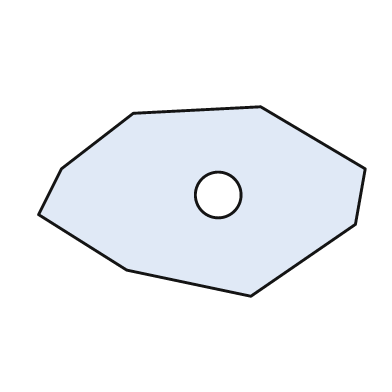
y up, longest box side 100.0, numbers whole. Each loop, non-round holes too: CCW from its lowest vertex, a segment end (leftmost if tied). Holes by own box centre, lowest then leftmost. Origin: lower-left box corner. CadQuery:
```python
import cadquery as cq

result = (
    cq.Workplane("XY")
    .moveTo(65.0, 0.0)
    .lineTo(97.0, 22.0)
    .lineTo(100.0, 39.0)
    .lineTo(68.0, 58.0)
    .lineTo(29.0, 56.0)
    .lineTo(7.0, 39.0)
    .lineTo(0.0, 25.0)
    .lineTo(27.0, 8.0)
    .close()
    .moveTo(55.0, 31.0)
    .circle(7.0)
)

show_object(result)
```